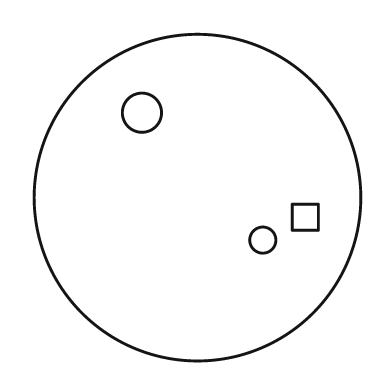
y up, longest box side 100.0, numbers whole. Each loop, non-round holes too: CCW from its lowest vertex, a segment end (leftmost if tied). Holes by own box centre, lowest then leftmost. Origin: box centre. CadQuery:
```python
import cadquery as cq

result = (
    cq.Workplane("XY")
    .moveTo(0.0, 0.0)
    .circle(50.0)
    .moveTo(20.0, -13.0)
    .circle(4.0)
    .moveTo(29.0, -10.0)
    .lineTo(37.0, -10.0)
    .lineTo(37.0, -2.0)
    .lineTo(29.0, -2.0)
    .close()
    .moveTo(-17.0, 26.0)
    .circle(6.0)
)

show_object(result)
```